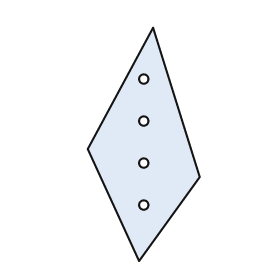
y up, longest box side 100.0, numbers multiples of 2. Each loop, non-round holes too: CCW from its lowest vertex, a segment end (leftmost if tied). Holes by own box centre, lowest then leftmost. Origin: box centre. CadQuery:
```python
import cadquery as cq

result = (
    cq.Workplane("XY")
    .moveTo(-2.0, -50.0)
    .lineTo(24.0, -14.0)
    .lineTo(4.0, 50.0)
    .lineTo(-24.0, -2.0)
    .close()
    .moveTo(0.0, -26.0)
    .circle(2.0)
    .moveTo(0.0, -8.0)
    .circle(2.0)
    .moveTo(0.0, 10.0)
    .circle(2.0)
    .moveTo(0.0, 28.0)
    .circle(2.0)
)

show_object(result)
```